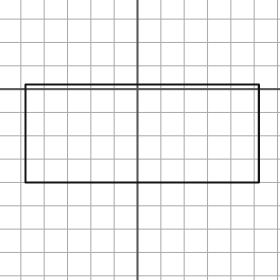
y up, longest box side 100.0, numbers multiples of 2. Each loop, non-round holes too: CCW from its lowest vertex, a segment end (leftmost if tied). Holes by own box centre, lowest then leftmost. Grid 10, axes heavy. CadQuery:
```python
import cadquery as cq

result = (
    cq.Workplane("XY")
    .moveTo(-48.0, -40.0)
    .lineTo(52.0, -40.0)
    .lineTo(52.0, 2.0)
    .lineTo(-48.0, 2.0)
    .close()
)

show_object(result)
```